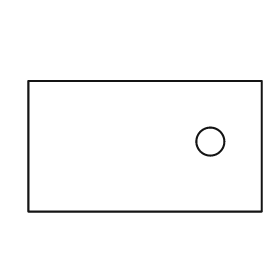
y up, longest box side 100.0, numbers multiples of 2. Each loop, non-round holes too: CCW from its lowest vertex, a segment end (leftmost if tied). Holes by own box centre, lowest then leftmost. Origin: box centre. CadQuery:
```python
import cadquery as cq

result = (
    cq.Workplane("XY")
    .moveTo(-50.0, -28.0)
    .lineTo(50.0, -28.0)
    .lineTo(50.0, 28.0)
    .lineTo(-50.0, 28.0)
    .close()
    .moveTo(28.0, 2.0)
    .circle(6.0)
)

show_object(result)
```